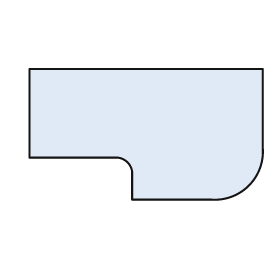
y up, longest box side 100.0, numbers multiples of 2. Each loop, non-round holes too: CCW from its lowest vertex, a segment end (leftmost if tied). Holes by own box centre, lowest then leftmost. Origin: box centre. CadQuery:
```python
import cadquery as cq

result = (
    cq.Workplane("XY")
    .moveTo(-6.0, -28.0)
    .lineTo(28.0, -28.0)
    .threePointArc((44.0, -22.0), (50.0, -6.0))
    .lineTo(50.0, 28.0)
    .lineTo(-50.0, 28.0)
    .lineTo(-50.0, -10.0)
    .lineTo(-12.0, -10.0)
    .threePointArc((-8.0, -12.0), (-6.0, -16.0))
    .close()
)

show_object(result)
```